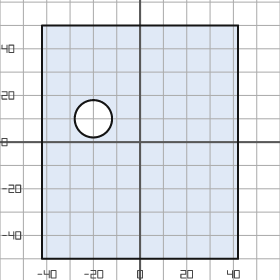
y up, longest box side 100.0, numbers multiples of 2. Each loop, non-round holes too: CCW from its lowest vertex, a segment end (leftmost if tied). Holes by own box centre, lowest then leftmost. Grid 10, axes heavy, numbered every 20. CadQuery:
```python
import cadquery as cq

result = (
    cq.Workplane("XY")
    .moveTo(-42.0, -50.0)
    .lineTo(42.0, -50.0)
    .lineTo(42.0, 50.0)
    .lineTo(-42.0, 50.0)
    .close()
    .moveTo(-20.0, 10.0)
    .circle(8.0)
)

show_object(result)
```